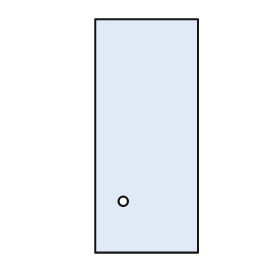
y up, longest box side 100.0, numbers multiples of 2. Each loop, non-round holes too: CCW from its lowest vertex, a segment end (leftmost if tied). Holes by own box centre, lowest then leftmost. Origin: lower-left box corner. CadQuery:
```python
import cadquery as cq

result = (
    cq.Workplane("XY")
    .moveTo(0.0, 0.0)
    .lineTo(44.0, 0.0)
    .lineTo(44.0, 100.0)
    .lineTo(0.0, 100.0)
    .close()
    .moveTo(12.0, 22.0)
    .circle(2.0)
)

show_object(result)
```